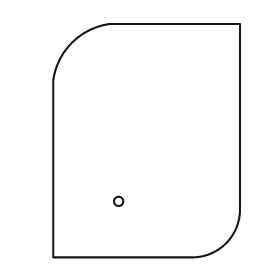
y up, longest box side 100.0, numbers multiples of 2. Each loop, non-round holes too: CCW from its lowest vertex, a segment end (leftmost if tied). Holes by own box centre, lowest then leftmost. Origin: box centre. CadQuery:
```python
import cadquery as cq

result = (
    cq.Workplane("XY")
    .moveTo(-40.0, -50.0)
    .lineTo(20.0, -50.0)
    .threePointArc((34.0, -44.0), (40.0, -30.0))
    .lineTo(40.0, 50.0)
    .lineTo(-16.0, 50.0)
    .threePointArc((-32.0, 42.0), (-40.0, 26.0))
    .close()
    .moveTo(-12.0, -26.0)
    .circle(2.0)
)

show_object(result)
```